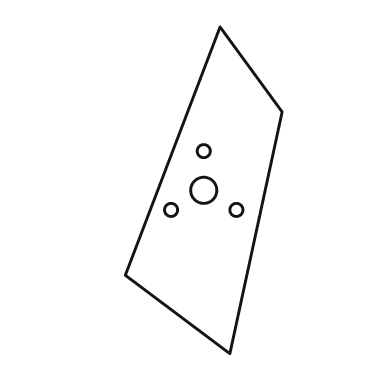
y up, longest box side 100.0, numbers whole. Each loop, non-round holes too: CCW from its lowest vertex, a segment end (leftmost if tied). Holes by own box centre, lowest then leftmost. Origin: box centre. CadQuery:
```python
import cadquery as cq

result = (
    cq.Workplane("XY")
    .moveTo(8.0, -50.0)
    .lineTo(24.0, 24.0)
    .lineTo(5.0, 50.0)
    .lineTo(-24.0, -26.0)
    .close()
    .moveTo(-10.0, -6.0)
    .circle(2.0)
    .moveTo(10.0, -6.0)
    .circle(2.0)
    .moveTo(0.0, 0.0)
    .circle(4.0)
    .moveTo(0.0, 12.0)
    .circle(2.0)
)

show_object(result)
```